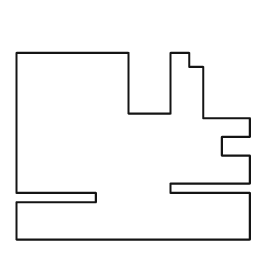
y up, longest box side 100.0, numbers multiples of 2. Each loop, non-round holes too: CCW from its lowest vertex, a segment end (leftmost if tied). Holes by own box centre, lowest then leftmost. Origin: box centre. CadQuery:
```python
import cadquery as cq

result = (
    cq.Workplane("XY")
    .moveTo(-50.0, -40.0)
    .lineTo(50.0, -40.0)
    .lineTo(50.0, -20.0)
    .lineTo(16.0, -20.0)
    .lineTo(16.0, -16.0)
    .lineTo(50.0, -16.0)
    .lineTo(50.0, -4.0)
    .lineTo(38.0, -4.0)
    .lineTo(38.0, 4.0)
    .lineTo(50.0, 4.0)
    .lineTo(50.0, 12.0)
    .lineTo(30.0, 12.0)
    .lineTo(30.0, 34.0)
    .lineTo(24.0, 34.0)
    .lineTo(24.0, 40.0)
    .lineTo(16.0, 40.0)
    .lineTo(16.0, 14.0)
    .lineTo(-2.0, 14.0)
    .lineTo(-2.0, 40.0)
    .lineTo(-50.0, 40.0)
    .lineTo(-50.0, -20.0)
    .lineTo(-16.0, -20.0)
    .lineTo(-16.0, -24.0)
    .lineTo(-50.0, -24.0)
    .close()
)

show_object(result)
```